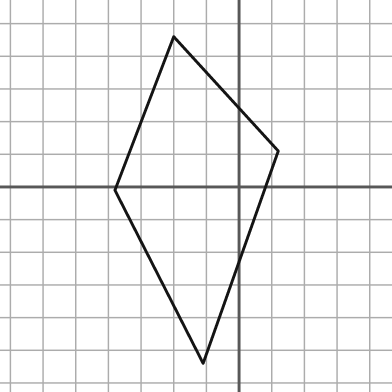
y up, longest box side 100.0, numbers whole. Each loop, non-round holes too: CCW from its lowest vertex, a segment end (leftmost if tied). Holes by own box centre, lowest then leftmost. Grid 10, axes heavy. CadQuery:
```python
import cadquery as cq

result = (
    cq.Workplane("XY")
    .moveTo(-11.0, -54.0)
    .lineTo(12.0, 11.0)
    .lineTo(-20.0, 46.0)
    .lineTo(-38.0, -1.0)
    .close()
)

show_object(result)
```